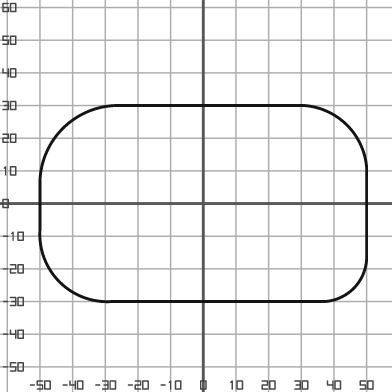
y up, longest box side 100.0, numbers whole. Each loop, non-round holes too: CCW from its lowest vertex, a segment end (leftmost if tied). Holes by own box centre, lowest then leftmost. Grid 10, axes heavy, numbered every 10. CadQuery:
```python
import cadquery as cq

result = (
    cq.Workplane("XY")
    .moveTo(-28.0, -30.0)
    .lineTo(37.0, -30.0)
    .threePointArc((46.0, -26.0), (50.0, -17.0))
    .lineTo(50.0, 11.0)
    .threePointArc((44.0, 24.0), (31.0, 30.0))
    .lineTo(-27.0, 30.0)
    .threePointArc((-43.0, 23.0), (-50.0, 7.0))
    .lineTo(-50.0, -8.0)
    .threePointArc((-44.0, -24.0), (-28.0, -30.0))
    .close()
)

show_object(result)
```